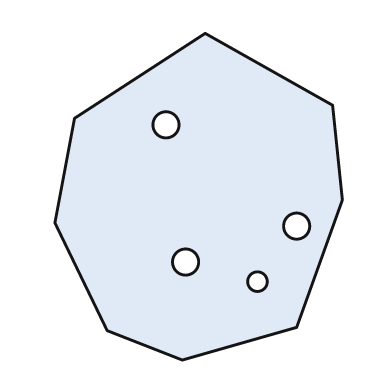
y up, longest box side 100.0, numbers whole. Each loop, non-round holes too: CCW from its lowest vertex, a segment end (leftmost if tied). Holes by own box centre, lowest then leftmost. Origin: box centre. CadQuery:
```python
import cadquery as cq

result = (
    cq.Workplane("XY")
    .moveTo(-5.0, -50.0)
    .lineTo(30.0, -40.0)
    .lineTo(44.0, -1.0)
    .lineTo(41.0, 28.0)
    .lineTo(2.0, 50.0)
    .lineTo(-38.0, 24.0)
    .lineTo(-44.0, -8.0)
    .lineTo(-28.0, -41.0)
    .close()
    .moveTo(18.0, -26.0)
    .circle(3.0)
    .moveTo(-4.0, -20.0)
    .circle(4.0)
    .moveTo(30.0, -9.0)
    .circle(4.0)
    .moveTo(-10.0, 22.0)
    .circle(4.0)
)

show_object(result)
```